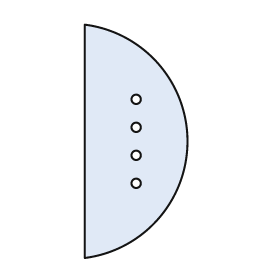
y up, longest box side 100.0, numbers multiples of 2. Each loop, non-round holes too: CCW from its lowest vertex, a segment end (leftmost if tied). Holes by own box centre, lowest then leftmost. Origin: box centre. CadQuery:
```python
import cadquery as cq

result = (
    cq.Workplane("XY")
    .moveTo(-22.0, -50.0)
    .threePointArc((22.0, 0.0), (-22.0, 50.0))
    .close()
    .moveTo(0.0, -18.0)
    .circle(2.0)
    .moveTo(0.0, -6.0)
    .circle(2.0)
    .moveTo(0.0, 6.0)
    .circle(2.0)
    .moveTo(0.0, 18.0)
    .circle(2.0)
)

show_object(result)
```